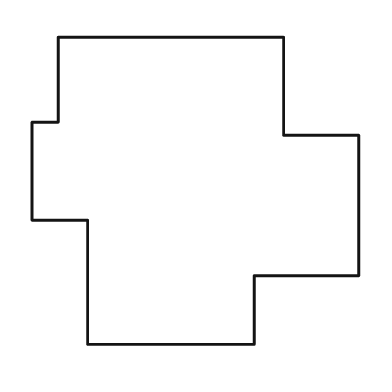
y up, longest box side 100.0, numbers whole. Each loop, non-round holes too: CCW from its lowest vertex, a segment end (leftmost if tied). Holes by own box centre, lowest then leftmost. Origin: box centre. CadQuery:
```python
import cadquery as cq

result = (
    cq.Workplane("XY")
    .moveTo(-33.0, -47.0)
    .lineTo(18.0, -47.0)
    .lineTo(18.0, -26.0)
    .lineTo(50.0, -26.0)
    .lineTo(50.0, 17.0)
    .lineTo(27.0, 17.0)
    .lineTo(27.0, 47.0)
    .lineTo(-42.0, 47.0)
    .lineTo(-42.0, 21.0)
    .lineTo(-50.0, 21.0)
    .lineTo(-50.0, -9.0)
    .lineTo(-33.0, -9.0)
    .close()
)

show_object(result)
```